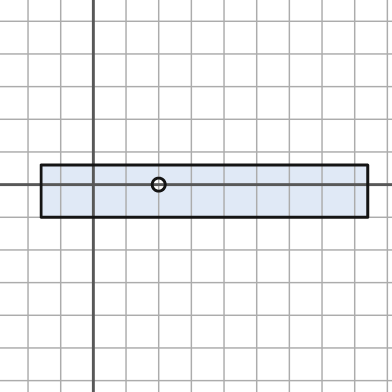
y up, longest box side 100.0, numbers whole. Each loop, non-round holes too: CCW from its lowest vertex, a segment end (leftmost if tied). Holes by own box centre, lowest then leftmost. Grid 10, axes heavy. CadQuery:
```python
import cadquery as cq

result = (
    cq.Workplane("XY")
    .moveTo(-16.0, -10.0)
    .lineTo(84.0, -10.0)
    .lineTo(84.0, 6.0)
    .lineTo(-16.0, 6.0)
    .close()
    .moveTo(20.0, 0.0)
    .circle(2.0)
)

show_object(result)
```